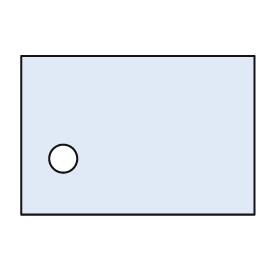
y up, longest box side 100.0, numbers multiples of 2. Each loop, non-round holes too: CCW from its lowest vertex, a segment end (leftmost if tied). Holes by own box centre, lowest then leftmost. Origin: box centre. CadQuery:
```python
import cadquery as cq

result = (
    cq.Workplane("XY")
    .moveTo(-50.0, -34.0)
    .lineTo(50.0, -34.0)
    .lineTo(50.0, 34.0)
    .lineTo(-50.0, 34.0)
    .close()
    .moveTo(-32.0, -10.0)
    .circle(6.0)
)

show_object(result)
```